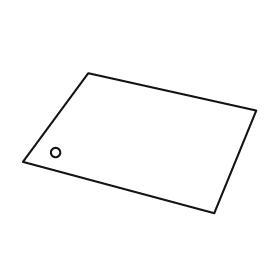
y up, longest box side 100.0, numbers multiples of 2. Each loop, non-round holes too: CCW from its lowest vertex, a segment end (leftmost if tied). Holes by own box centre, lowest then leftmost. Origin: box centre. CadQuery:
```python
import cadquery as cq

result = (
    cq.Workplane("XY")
    .moveTo(32.0, -30.0)
    .lineTo(50.0, 14.0)
    .lineTo(-22.0, 30.0)
    .lineTo(-50.0, -8.0)
    .close()
    .moveTo(-36.0, -4.0)
    .circle(2.0)
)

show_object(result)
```